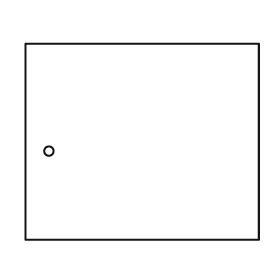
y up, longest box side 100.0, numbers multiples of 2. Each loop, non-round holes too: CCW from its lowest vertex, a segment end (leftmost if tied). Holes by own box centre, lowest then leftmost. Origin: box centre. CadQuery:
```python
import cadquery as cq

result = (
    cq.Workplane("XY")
    .moveTo(-50.0, -42.0)
    .lineTo(50.0, -42.0)
    .lineTo(50.0, 42.0)
    .lineTo(-50.0, 42.0)
    .close()
    .moveTo(-40.0, -4.0)
    .circle(2.0)
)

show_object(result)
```